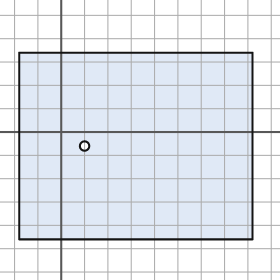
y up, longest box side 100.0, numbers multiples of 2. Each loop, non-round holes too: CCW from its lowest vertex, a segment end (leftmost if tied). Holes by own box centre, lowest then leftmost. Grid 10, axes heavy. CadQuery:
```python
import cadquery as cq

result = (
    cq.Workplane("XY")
    .moveTo(-18.0, -46.0)
    .lineTo(82.0, -46.0)
    .lineTo(82.0, 34.0)
    .lineTo(-18.0, 34.0)
    .close()
    .moveTo(10.0, -6.0)
    .circle(2.0)
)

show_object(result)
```